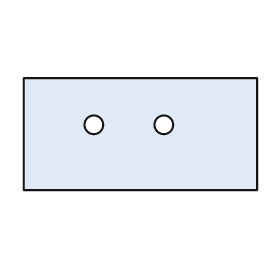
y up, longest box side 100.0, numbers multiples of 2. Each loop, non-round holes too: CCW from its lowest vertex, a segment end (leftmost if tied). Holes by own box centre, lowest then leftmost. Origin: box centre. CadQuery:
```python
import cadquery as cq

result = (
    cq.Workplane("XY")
    .moveTo(-50.0, -24.0)
    .lineTo(50.0, -24.0)
    .lineTo(50.0, 24.0)
    .lineTo(-50.0, 24.0)
    .close()
    .moveTo(-20.0, 4.0)
    .circle(4.0)
    .moveTo(10.0, 4.0)
    .circle(4.0)
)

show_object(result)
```